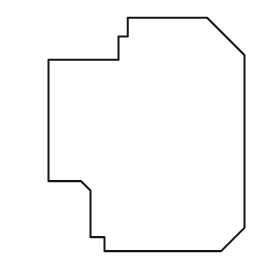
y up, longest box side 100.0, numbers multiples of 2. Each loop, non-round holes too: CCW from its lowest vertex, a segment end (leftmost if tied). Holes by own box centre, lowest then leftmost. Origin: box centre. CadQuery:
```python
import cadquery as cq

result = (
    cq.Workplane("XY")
    .moveTo(-18.0, -50.0)
    .lineTo(32.0, -50.0)
    .lineTo(42.0, -40.0)
    .lineTo(42.0, 34.0)
    .lineTo(26.0, 50.0)
    .lineTo(-8.0, 50.0)
    .lineTo(-8.0, 42.0)
    .lineTo(-12.0, 42.0)
    .lineTo(-12.0, 32.0)
    .lineTo(-42.0, 32.0)
    .lineTo(-42.0, -20.0)
    .lineTo(-28.0, -20.0)
    .lineTo(-24.0, -24.0)
    .lineTo(-24.0, -44.0)
    .lineTo(-18.0, -44.0)
    .close()
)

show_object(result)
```